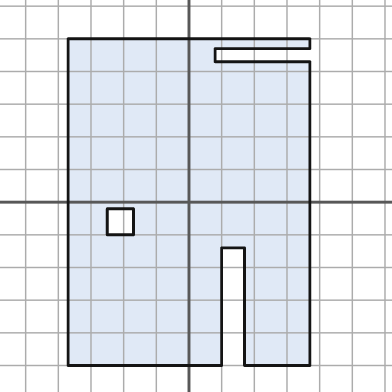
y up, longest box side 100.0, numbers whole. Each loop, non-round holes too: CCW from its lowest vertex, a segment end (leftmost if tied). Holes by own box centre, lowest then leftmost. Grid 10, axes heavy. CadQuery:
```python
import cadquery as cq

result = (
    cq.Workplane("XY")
    .moveTo(-37.0, -50.0)
    .lineTo(10.0, -50.0)
    .lineTo(10.0, -14.0)
    .lineTo(17.0, -14.0)
    .lineTo(17.0, -50.0)
    .lineTo(37.0, -50.0)
    .lineTo(37.0, 43.0)
    .lineTo(8.0, 43.0)
    .lineTo(8.0, 47.0)
    .lineTo(37.0, 47.0)
    .lineTo(37.0, 50.0)
    .lineTo(-37.0, 50.0)
    .close()
    .moveTo(-25.0, -10.0)
    .lineTo(-17.0, -10.0)
    .lineTo(-17.0, -2.0)
    .lineTo(-25.0, -2.0)
    .close()
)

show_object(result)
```